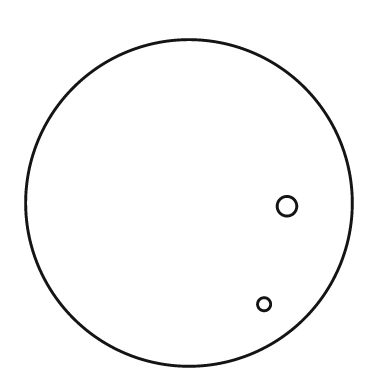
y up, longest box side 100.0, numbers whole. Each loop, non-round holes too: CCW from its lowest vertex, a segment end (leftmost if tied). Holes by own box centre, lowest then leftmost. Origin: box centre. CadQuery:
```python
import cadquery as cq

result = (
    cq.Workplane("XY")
    .moveTo(0.0, 0.0)
    .circle(50.0)
    .moveTo(23.0, -31.0)
    .circle(2.0)
    .moveTo(30.0, -1.0)
    .circle(3.0)
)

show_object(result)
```